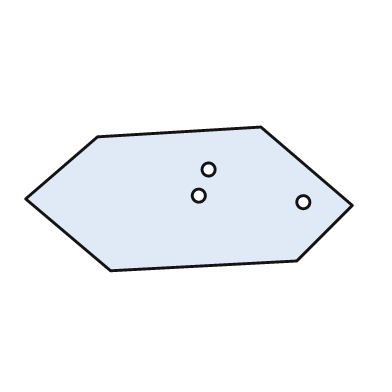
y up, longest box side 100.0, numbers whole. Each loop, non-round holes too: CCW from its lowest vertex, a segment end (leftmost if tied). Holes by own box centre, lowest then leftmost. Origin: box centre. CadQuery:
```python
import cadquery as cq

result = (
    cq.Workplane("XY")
    .moveTo(-24.0, -22.0)
    .lineTo(33.0, -19.0)
    .lineTo(50.0, -2.0)
    .lineTo(22.0, 22.0)
    .lineTo(-28.0, 19.0)
    .lineTo(-50.0, 0.0)
    .close()
    .moveTo(35.0, -1.0)
    .circle(2.0)
    .moveTo(3.0, 1.0)
    .circle(2.0)
    .moveTo(6.0, 9.0)
    .circle(2.0)
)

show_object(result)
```